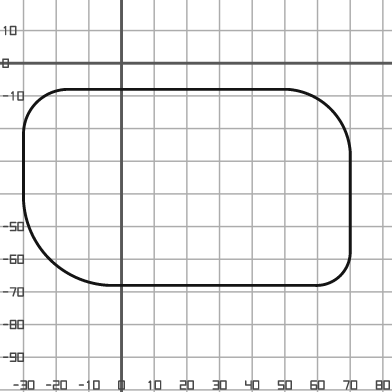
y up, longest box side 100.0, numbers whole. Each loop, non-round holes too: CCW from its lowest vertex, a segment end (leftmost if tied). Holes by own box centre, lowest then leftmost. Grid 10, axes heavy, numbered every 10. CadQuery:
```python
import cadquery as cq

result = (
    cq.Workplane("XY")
    .moveTo(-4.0, -68.0)
    .lineTo(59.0, -68.0)
    .threePointArc((67.0, -65.0), (70.0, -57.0))
    .lineTo(70.0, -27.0)
    .threePointArc((64.0, -14.0), (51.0, -8.0))
    .lineTo(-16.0, -8.0)
    .threePointArc((-26.0, -12.0), (-30.0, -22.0))
    .lineTo(-30.0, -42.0)
    .threePointArc((-22.0, -60.0), (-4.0, -68.0))
    .close()
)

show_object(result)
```